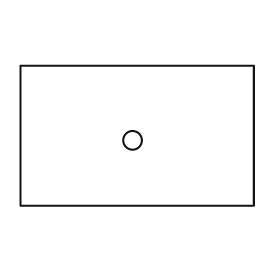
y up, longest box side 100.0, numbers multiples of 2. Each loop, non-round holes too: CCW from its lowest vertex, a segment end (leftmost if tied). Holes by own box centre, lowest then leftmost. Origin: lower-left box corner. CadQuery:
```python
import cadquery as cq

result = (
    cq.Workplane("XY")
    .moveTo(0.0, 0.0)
    .lineTo(100.0, 0.0)
    .lineTo(100.0, 60.0)
    .lineTo(0.0, 60.0)
    .close()
    .moveTo(48.0, 28.0)
    .circle(4.0)
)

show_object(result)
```